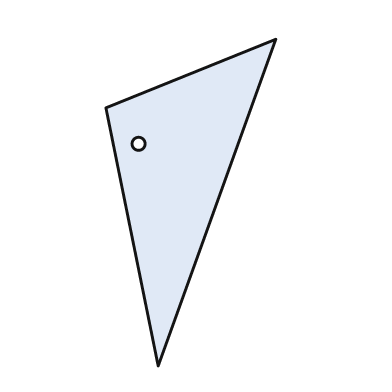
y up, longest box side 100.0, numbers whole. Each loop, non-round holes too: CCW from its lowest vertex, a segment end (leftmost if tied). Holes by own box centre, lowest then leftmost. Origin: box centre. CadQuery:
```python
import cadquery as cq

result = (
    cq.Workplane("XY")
    .moveTo(-10.0, -50.0)
    .lineTo(26.0, 50.0)
    .lineTo(-26.0, 29.0)
    .close()
    .moveTo(-16.0, 18.0)
    .circle(2.0)
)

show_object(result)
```